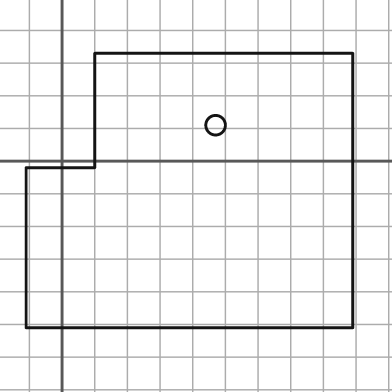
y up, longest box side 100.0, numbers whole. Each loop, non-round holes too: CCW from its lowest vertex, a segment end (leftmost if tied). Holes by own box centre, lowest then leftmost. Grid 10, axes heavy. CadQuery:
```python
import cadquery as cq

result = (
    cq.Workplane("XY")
    .moveTo(-11.0, -51.0)
    .lineTo(89.0, -51.0)
    .lineTo(89.0, 33.0)
    .lineTo(10.0, 33.0)
    .lineTo(10.0, -2.0)
    .lineTo(-11.0, -2.0)
    .close()
    .moveTo(47.0, 11.0)
    .circle(3.0)
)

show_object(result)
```